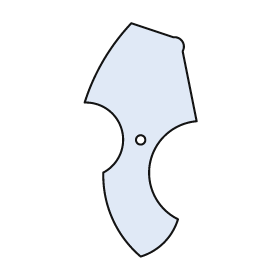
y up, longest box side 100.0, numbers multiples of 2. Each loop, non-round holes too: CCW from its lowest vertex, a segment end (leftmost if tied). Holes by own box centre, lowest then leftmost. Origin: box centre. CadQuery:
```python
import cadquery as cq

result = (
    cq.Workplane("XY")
    .moveTo(0.0, -50.0)
    .threePointArc((10.0, -44.0), (16.0, -34.0))
    .threePointArc((4.0, -10.0), (24.0, 8.0))
    .lineTo(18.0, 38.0)
    .threePointArc((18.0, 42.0), (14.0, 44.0))
    .lineTo(-4.0, 50.0)
    .threePointArc((-16.0, 34.0), (-24.0, 16.0))
    .threePointArc((-8.0, 4.0), (-16.0, -14.0))
    .threePointArc((-12.0, -34.0), (0.0, -50.0))
    .close()
    .moveTo(0.0, 0.0)
    .circle(2.0)
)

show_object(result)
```